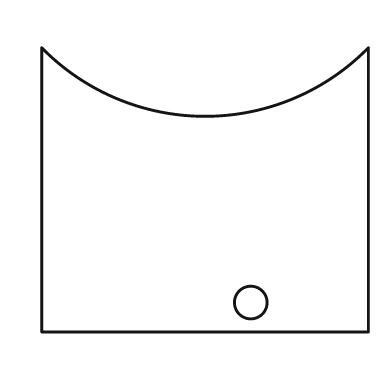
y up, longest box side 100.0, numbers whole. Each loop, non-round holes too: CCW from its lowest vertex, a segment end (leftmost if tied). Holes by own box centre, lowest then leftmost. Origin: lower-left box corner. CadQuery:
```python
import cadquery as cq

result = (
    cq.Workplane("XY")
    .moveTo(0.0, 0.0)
    .lineTo(100.0, 0.0)
    .lineTo(100.0, 87.0)
    .threePointArc((50.0, 66.0), (0.0, 87.0))
    .close()
    .moveTo(64.0, 9.0)
    .circle(5.0)
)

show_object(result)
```